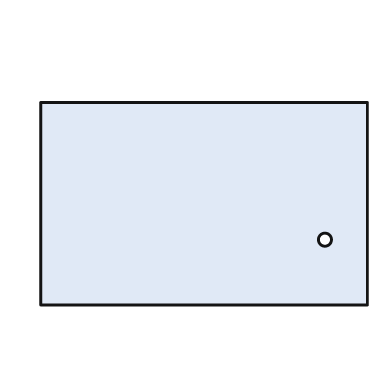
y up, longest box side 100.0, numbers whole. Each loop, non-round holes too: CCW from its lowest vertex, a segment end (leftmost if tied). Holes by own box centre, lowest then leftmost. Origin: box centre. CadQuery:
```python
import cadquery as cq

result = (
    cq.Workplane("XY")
    .moveTo(-50.0, -31.0)
    .lineTo(50.0, -31.0)
    .lineTo(50.0, 31.0)
    .lineTo(-50.0, 31.0)
    .close()
    .moveTo(37.0, -11.0)
    .circle(2.0)
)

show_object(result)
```